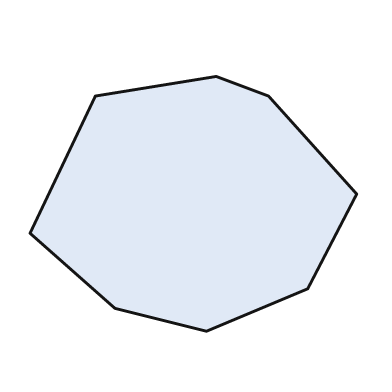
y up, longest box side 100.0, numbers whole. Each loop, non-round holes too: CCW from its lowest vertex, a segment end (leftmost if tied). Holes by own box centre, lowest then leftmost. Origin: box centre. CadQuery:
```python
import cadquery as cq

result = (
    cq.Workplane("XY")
    .moveTo(4.0, -39.0)
    .lineTo(35.0, -26.0)
    .lineTo(50.0, 3.0)
    .lineTo(23.0, 33.0)
    .lineTo(7.0, 39.0)
    .lineTo(-30.0, 33.0)
    .lineTo(-50.0, -9.0)
    .lineTo(-24.0, -32.0)
    .close()
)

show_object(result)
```